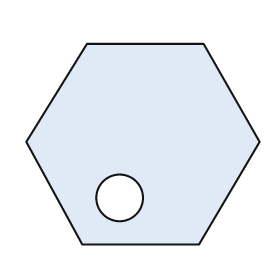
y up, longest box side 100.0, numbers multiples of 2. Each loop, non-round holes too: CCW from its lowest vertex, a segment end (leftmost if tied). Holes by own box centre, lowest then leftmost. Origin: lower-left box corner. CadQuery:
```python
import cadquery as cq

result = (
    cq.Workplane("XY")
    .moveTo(24.0, 0.0)
    .lineTo(74.0, 0.0)
    .lineTo(100.0, 44.0)
    .lineTo(76.0, 86.0)
    .lineTo(26.0, 86.0)
    .lineTo(0.0, 44.0)
    .close()
    .moveTo(40.0, 20.0)
    .circle(10.0)
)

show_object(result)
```